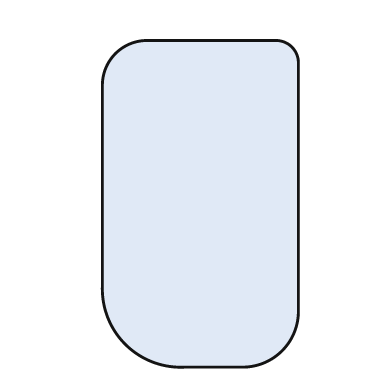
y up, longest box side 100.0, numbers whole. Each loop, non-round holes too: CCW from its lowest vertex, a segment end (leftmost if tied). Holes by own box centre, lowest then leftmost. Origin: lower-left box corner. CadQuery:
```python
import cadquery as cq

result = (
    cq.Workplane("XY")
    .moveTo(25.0, 0.0)
    .lineTo(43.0, 0.0)
    .threePointArc((55.0, 5.0), (60.0, 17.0))
    .lineTo(60.0, 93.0)
    .threePointArc((58.0, 98.0), (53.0, 100.0))
    .lineTo(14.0, 100.0)
    .threePointArc((4.0, 96.0), (0.0, 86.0))
    .lineTo(0.0, 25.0)
    .threePointArc((7.0, 7.0), (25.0, 0.0))
    .close()
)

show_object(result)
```